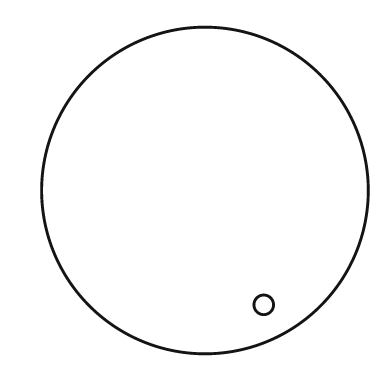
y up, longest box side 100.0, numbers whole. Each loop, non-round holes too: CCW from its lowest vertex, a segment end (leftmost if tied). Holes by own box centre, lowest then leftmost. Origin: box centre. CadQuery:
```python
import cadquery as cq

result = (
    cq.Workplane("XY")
    .moveTo(0.0, 0.0)
    .circle(50.0)
    .moveTo(18.0, -35.0)
    .circle(3.0)
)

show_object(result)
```